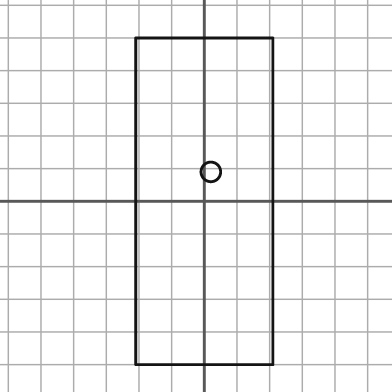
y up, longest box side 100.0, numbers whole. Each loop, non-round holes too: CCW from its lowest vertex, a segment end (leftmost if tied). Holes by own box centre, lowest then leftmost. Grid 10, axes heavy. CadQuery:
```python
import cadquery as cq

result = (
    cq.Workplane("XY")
    .moveTo(-21.0, -50.0)
    .lineTo(21.0, -50.0)
    .lineTo(21.0, 50.0)
    .lineTo(-21.0, 50.0)
    .close()
    .moveTo(2.0, 9.0)
    .circle(3.0)
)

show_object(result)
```